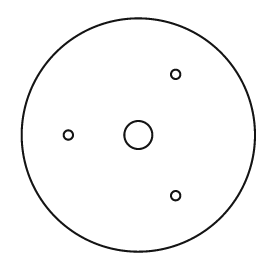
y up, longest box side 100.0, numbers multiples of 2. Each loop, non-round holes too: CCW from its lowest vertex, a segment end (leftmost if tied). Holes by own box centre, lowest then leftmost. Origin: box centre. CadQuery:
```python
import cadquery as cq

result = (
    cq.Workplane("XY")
    .moveTo(0.0, 0.0)
    .circle(50.0)
    .moveTo(16.0, -26.0)
    .circle(2.0)
    .moveTo(-30.0, 0.0)
    .circle(2.0)
    .moveTo(0.0, 0.0)
    .circle(6.0)
    .moveTo(16.0, 26.0)
    .circle(2.0)
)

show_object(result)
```